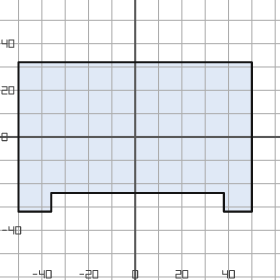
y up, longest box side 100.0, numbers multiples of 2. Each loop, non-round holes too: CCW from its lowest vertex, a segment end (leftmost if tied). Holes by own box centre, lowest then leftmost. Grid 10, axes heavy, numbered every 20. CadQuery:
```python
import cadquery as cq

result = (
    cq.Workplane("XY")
    .moveTo(-50.0, -32.0)
    .lineTo(-36.0, -32.0)
    .lineTo(-36.0, -24.0)
    .lineTo(38.0, -24.0)
    .lineTo(38.0, -32.0)
    .lineTo(50.0, -32.0)
    .lineTo(50.0, 32.0)
    .lineTo(-50.0, 32.0)
    .close()
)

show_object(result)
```